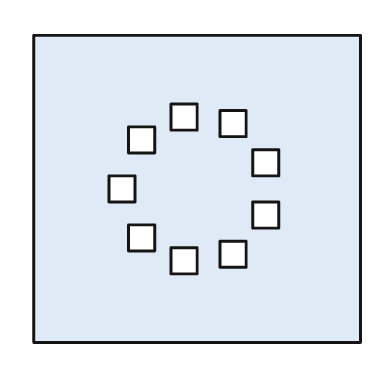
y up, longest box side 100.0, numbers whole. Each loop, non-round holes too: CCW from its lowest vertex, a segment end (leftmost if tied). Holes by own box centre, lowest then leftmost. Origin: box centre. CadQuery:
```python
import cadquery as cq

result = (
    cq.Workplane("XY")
    .moveTo(-50.0, -47.0)
    .lineTo(50.0, -47.0)
    .lineTo(50.0, 47.0)
    .lineTo(-50.0, 47.0)
    .close()
    .moveTo(-8.0, -26.0)
    .lineTo(0.0, -26.0)
    .lineTo(0.0, -18.0)
    .lineTo(-8.0, -18.0)
    .close()
    .moveTo(7.0, -24.0)
    .lineTo(15.0, -24.0)
    .lineTo(15.0, -16.0)
    .lineTo(7.0, -16.0)
    .close()
    .moveTo(-21.0, -19.0)
    .lineTo(-13.0, -19.0)
    .lineTo(-13.0, -11.0)
    .lineTo(-21.0, -11.0)
    .close()
    .moveTo(17.0, -12.0)
    .lineTo(25.0, -12.0)
    .lineTo(25.0, -4.0)
    .lineTo(17.0, -4.0)
    .close()
    .moveTo(-27.0, -4.0)
    .lineTo(-19.0, -4.0)
    .lineTo(-19.0, 4.0)
    .lineTo(-27.0, 4.0)
    .close()
    .moveTo(17.0, 4.0)
    .lineTo(25.0, 4.0)
    .lineTo(25.0, 12.0)
    .lineTo(17.0, 12.0)
    .close()
    .moveTo(-21.0, 11.0)
    .lineTo(-13.0, 11.0)
    .lineTo(-13.0, 19.0)
    .lineTo(-21.0, 19.0)
    .close()
    .moveTo(7.0, 16.0)
    .lineTo(15.0, 16.0)
    .lineTo(15.0, 24.0)
    .lineTo(7.0, 24.0)
    .close()
    .moveTo(-8.0, 18.0)
    .lineTo(0.0, 18.0)
    .lineTo(0.0, 26.0)
    .lineTo(-8.0, 26.0)
    .close()
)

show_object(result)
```